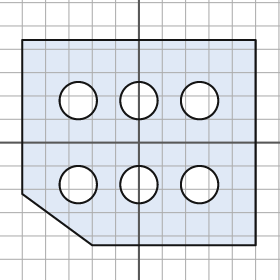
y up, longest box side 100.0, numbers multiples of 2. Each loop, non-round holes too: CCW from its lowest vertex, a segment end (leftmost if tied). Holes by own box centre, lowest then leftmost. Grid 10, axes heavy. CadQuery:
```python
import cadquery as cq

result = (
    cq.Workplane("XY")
    .moveTo(-20.0, -44.0)
    .lineTo(50.0, -44.0)
    .lineTo(50.0, 44.0)
    .lineTo(-50.0, 44.0)
    .lineTo(-50.0, -22.0)
    .close()
    .moveTo(-26.0, -18.0)
    .circle(8.0)
    .moveTo(0.0, -18.0)
    .circle(8.0)
    .moveTo(26.0, -18.0)
    .circle(8.0)
    .moveTo(-26.0, 18.0)
    .circle(8.0)
    .moveTo(0.0, 18.0)
    .circle(8.0)
    .moveTo(26.0, 18.0)
    .circle(8.0)
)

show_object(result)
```